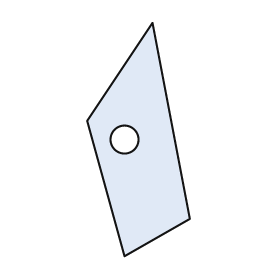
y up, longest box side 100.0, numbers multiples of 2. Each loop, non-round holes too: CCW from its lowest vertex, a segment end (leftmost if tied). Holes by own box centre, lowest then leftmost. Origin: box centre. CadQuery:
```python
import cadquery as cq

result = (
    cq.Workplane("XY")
    .moveTo(-6.0, -50.0)
    .lineTo(22.0, -34.0)
    .lineTo(6.0, 50.0)
    .lineTo(-22.0, 8.0)
    .close()
    .moveTo(-6.0, 0.0)
    .circle(6.0)
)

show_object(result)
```